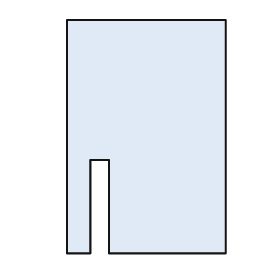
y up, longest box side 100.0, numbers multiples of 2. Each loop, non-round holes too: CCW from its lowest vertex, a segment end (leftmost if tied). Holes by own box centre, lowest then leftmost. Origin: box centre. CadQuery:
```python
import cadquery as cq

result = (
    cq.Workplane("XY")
    .moveTo(-34.0, -50.0)
    .lineTo(-24.0, -50.0)
    .lineTo(-24.0, -10.0)
    .lineTo(-16.0, -10.0)
    .lineTo(-16.0, -50.0)
    .lineTo(34.0, -50.0)
    .lineTo(34.0, 50.0)
    .lineTo(-34.0, 50.0)
    .close()
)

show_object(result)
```